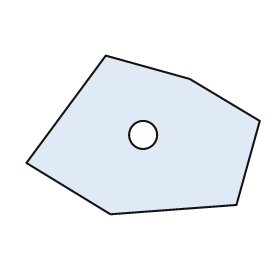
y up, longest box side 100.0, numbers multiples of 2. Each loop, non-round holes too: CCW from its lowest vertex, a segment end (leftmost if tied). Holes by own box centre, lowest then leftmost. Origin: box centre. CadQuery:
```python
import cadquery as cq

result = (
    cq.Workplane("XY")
    .moveTo(-14.0, -34.0)
    .lineTo(40.0, -30.0)
    .lineTo(50.0, 6.0)
    .lineTo(20.0, 24.0)
    .lineTo(-16.0, 34.0)
    .lineTo(-50.0, -12.0)
    .close()
    .moveTo(0.0, 0.0)
    .circle(6.0)
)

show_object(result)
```